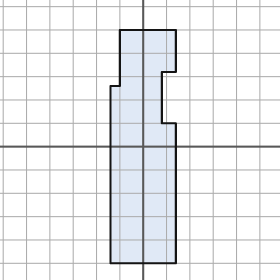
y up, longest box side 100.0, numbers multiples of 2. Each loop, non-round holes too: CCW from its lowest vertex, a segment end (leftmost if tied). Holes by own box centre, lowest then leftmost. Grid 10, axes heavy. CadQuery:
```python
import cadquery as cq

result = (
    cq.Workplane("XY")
    .moveTo(-14.0, -50.0)
    .lineTo(14.0, -50.0)
    .lineTo(14.0, 10.0)
    .lineTo(8.0, 10.0)
    .lineTo(8.0, 32.0)
    .lineTo(14.0, 32.0)
    .lineTo(14.0, 50.0)
    .lineTo(-10.0, 50.0)
    .lineTo(-10.0, 26.0)
    .lineTo(-14.0, 26.0)
    .close()
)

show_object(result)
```